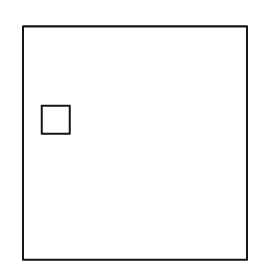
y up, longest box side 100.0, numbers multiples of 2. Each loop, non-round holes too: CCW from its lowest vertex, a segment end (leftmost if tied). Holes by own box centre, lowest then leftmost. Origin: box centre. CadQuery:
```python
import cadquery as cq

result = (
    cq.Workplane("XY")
    .moveTo(-48.0, -50.0)
    .lineTo(48.0, -50.0)
    .lineTo(48.0, 50.0)
    .lineTo(-48.0, 50.0)
    .close()
    .moveTo(-40.0, 4.0)
    .lineTo(-28.0, 4.0)
    .lineTo(-28.0, 16.0)
    .lineTo(-40.0, 16.0)
    .close()
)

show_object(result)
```